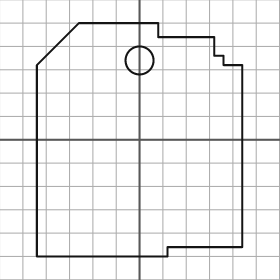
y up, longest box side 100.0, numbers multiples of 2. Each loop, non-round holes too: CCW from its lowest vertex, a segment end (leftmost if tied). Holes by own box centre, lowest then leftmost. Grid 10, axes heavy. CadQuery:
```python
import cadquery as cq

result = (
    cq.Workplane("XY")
    .moveTo(-44.0, -50.0)
    .lineTo(12.0, -50.0)
    .lineTo(12.0, -46.0)
    .lineTo(44.0, -46.0)
    .lineTo(44.0, 32.0)
    .lineTo(36.0, 32.0)
    .lineTo(36.0, 36.0)
    .lineTo(32.0, 36.0)
    .lineTo(32.0, 44.0)
    .lineTo(8.0, 44.0)
    .lineTo(8.0, 50.0)
    .lineTo(-26.0, 50.0)
    .lineTo(-44.0, 32.0)
    .close()
    .moveTo(0.0, 34.0)
    .circle(6.0)
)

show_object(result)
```